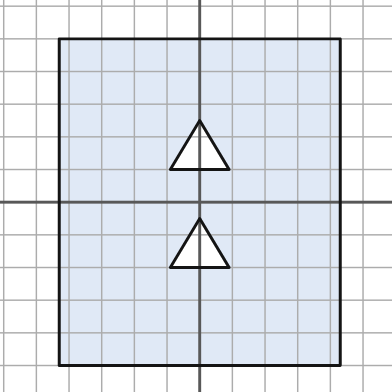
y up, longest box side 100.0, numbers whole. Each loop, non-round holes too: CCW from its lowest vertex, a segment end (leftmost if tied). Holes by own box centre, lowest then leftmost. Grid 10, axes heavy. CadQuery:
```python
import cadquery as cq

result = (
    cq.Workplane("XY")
    .moveTo(-43.0, -50.0)
    .lineTo(43.0, -50.0)
    .lineTo(43.0, 50.0)
    .lineTo(-43.0, 50.0)
    .close()
    .moveTo(-9.0, -20.0)
    .lineTo(9.0, -20.0)
    .lineTo(0.0, -5.0)
    .close()
    .moveTo(-9.0, 10.0)
    .lineTo(9.0, 10.0)
    .lineTo(0.0, 25.0)
    .close()
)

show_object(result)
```